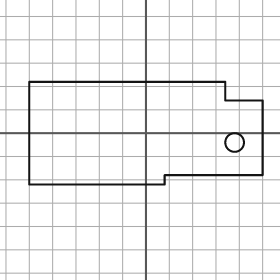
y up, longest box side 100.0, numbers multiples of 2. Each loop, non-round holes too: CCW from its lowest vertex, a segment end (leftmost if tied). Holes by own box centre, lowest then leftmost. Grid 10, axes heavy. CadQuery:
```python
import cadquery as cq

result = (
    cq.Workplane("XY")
    .moveTo(-50.0, -22.0)
    .lineTo(8.0, -22.0)
    .lineTo(8.0, -18.0)
    .lineTo(50.0, -18.0)
    .lineTo(50.0, 14.0)
    .lineTo(34.0, 14.0)
    .lineTo(34.0, 22.0)
    .lineTo(-50.0, 22.0)
    .close()
    .moveTo(38.0, -4.0)
    .circle(4.0)
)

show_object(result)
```